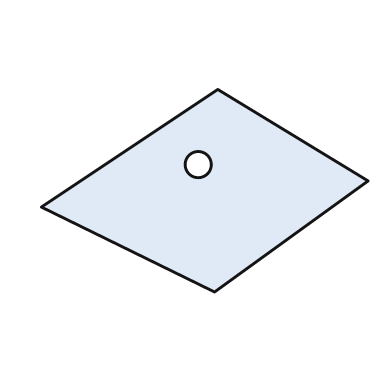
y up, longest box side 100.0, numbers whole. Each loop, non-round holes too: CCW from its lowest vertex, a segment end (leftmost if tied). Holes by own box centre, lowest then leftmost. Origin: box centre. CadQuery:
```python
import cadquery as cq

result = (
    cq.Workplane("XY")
    .moveTo(3.0, -31.0)
    .lineTo(50.0, 3.0)
    .lineTo(4.0, 31.0)
    .lineTo(-50.0, -5.0)
    .close()
    .moveTo(-2.0, 8.0)
    .circle(4.0)
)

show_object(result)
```